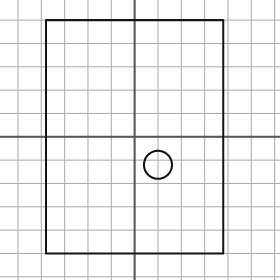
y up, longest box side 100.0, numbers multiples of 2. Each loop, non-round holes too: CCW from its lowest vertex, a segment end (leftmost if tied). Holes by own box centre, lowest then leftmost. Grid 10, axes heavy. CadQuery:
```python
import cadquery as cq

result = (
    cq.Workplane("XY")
    .moveTo(-38.0, -50.0)
    .lineTo(38.0, -50.0)
    .lineTo(38.0, 50.0)
    .lineTo(-38.0, 50.0)
    .close()
    .moveTo(10.0, -12.0)
    .circle(6.0)
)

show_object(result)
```